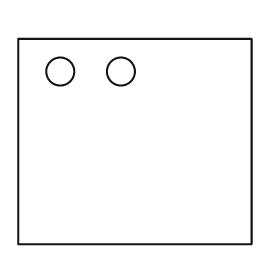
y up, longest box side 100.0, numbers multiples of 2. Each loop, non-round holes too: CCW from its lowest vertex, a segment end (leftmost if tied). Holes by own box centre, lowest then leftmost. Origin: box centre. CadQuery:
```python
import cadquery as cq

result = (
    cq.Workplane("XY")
    .moveTo(-50.0, -44.0)
    .lineTo(50.0, -44.0)
    .lineTo(50.0, 44.0)
    .lineTo(-50.0, 44.0)
    .close()
    .moveTo(-32.0, 30.0)
    .circle(6.0)
    .moveTo(-6.0, 30.0)
    .circle(6.0)
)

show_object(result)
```